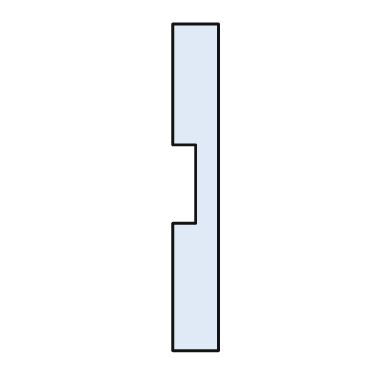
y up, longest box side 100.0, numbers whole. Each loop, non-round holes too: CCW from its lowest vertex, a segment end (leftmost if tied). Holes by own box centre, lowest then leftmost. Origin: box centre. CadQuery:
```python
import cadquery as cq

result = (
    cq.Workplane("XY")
    .moveTo(-7.0, -50.0)
    .lineTo(7.0, -50.0)
    .lineTo(7.0, 50.0)
    .lineTo(-7.0, 50.0)
    .lineTo(-7.0, 13.0)
    .lineTo(0.0, 13.0)
    .lineTo(0.0, -11.0)
    .lineTo(-7.0, -11.0)
    .close()
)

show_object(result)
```